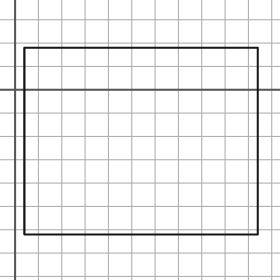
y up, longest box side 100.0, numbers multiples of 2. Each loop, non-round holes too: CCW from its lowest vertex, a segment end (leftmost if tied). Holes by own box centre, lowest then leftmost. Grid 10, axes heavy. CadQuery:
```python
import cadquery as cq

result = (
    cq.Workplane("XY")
    .moveTo(4.0, -62.0)
    .lineTo(104.0, -62.0)
    .lineTo(104.0, 18.0)
    .lineTo(4.0, 18.0)
    .close()
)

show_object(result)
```